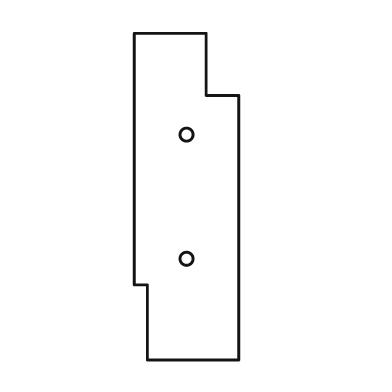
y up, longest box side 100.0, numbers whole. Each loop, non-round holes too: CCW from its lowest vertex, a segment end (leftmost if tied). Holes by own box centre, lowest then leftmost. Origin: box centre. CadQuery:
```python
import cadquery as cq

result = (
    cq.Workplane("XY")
    .moveTo(-12.0, -50.0)
    .lineTo(16.0, -50.0)
    .lineTo(16.0, 31.0)
    .lineTo(6.0, 31.0)
    .lineTo(6.0, 50.0)
    .lineTo(-16.0, 50.0)
    .lineTo(-16.0, -27.0)
    .lineTo(-12.0, -27.0)
    .close()
    .moveTo(0.0, -19.0)
    .circle(2.0)
    .moveTo(0.0, 19.0)
    .circle(2.0)
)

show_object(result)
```